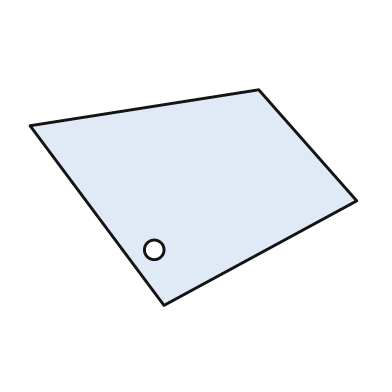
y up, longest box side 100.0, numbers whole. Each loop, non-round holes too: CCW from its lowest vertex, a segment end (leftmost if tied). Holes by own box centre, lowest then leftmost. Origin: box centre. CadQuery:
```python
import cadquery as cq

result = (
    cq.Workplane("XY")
    .moveTo(-9.0, -33.0)
    .lineTo(50.0, -1.0)
    .lineTo(20.0, 33.0)
    .lineTo(-50.0, 22.0)
    .close()
    .moveTo(-12.0, -16.0)
    .circle(3.0)
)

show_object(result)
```